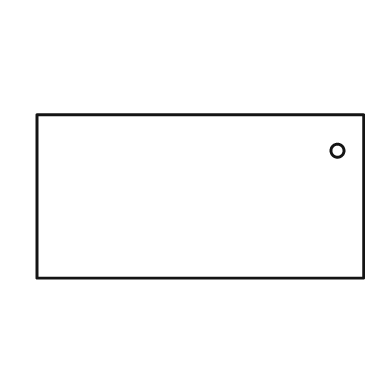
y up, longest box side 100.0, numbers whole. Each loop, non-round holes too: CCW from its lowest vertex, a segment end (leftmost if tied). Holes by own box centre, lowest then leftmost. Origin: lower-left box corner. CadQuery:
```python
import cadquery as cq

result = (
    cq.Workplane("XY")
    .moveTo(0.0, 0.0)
    .lineTo(100.0, 0.0)
    .lineTo(100.0, 50.0)
    .lineTo(0.0, 50.0)
    .close()
    .moveTo(92.0, 39.0)
    .circle(2.0)
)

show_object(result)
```